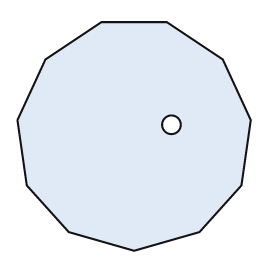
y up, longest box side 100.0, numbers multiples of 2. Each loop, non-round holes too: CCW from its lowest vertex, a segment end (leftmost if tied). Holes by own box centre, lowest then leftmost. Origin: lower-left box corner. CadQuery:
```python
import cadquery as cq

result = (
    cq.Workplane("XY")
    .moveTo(50.0, 0.0)
    .lineTo(78.0, 8.0)
    .lineTo(96.0, 28.0)
    .lineTo(100.0, 56.0)
    .lineTo(88.0, 82.0)
    .lineTo(64.0, 98.0)
    .lineTo(36.0, 98.0)
    .lineTo(12.0, 82.0)
    .lineTo(0.0, 56.0)
    .lineTo(4.0, 28.0)
    .lineTo(22.0, 8.0)
    .close()
    .moveTo(66.0, 54.0)
    .circle(4.0)
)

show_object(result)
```